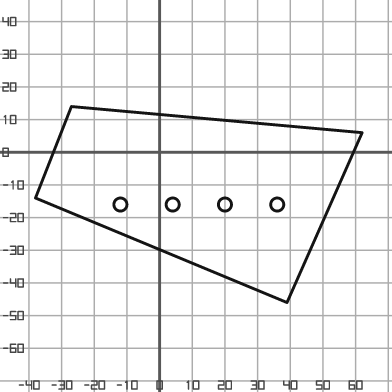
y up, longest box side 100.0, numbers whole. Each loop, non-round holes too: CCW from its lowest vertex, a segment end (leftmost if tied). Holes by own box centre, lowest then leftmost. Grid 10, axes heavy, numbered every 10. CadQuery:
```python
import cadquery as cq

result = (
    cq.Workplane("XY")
    .moveTo(39.0, -46.0)
    .lineTo(62.0, 6.0)
    .lineTo(-27.0, 14.0)
    .lineTo(-38.0, -14.0)
    .close()
    .moveTo(-12.0, -16.0)
    .circle(2.0)
    .moveTo(4.0, -16.0)
    .circle(2.0)
    .moveTo(20.0, -16.0)
    .circle(2.0)
    .moveTo(36.0, -16.0)
    .circle(2.0)
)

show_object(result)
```